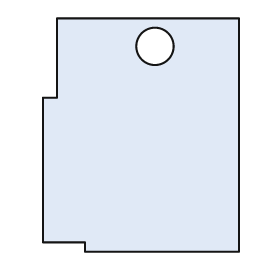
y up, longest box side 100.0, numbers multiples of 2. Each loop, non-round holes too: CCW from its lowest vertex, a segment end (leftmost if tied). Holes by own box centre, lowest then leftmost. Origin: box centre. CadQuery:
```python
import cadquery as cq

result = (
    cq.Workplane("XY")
    .moveTo(-24.0, -50.0)
    .lineTo(42.0, -50.0)
    .lineTo(42.0, 50.0)
    .lineTo(-36.0, 50.0)
    .lineTo(-36.0, 16.0)
    .lineTo(-42.0, 16.0)
    .lineTo(-42.0, -46.0)
    .lineTo(-24.0, -46.0)
    .close()
    .moveTo(6.0, 38.0)
    .circle(8.0)
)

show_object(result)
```